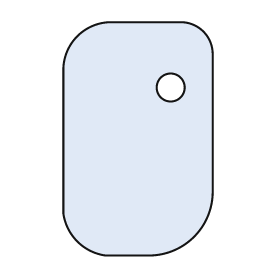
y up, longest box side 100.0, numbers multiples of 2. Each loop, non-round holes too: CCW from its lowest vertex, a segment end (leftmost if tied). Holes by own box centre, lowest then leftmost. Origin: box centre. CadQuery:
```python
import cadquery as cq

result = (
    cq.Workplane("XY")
    .moveTo(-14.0, -50.0)
    .lineTo(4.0, -50.0)
    .threePointArc((24.0, -42.0), (32.0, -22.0))
    .lineTo(32.0, 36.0)
    .threePointArc((28.0, 46.0), (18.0, 50.0))
    .lineTo(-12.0, 50.0)
    .threePointArc((-26.0, 44.0), (-32.0, 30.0))
    .lineTo(-32.0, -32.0)
    .threePointArc((-26.0, -44.0), (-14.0, -50.0))
    .close()
    .moveTo(14.0, 22.0)
    .circle(6.0)
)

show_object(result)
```